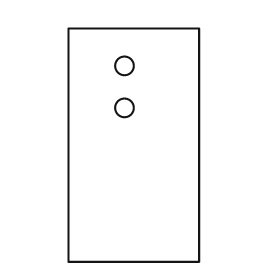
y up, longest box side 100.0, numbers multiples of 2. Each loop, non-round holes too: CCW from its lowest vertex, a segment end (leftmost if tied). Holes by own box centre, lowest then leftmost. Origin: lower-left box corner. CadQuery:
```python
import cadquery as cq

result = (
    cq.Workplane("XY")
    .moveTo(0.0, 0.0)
    .lineTo(56.0, 0.0)
    .lineTo(56.0, 100.0)
    .lineTo(0.0, 100.0)
    .close()
    .moveTo(24.0, 66.0)
    .circle(4.0)
    .moveTo(24.0, 84.0)
    .circle(4.0)
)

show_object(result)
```